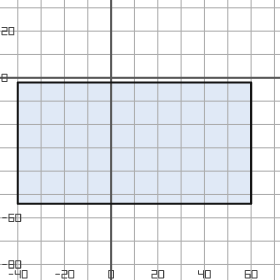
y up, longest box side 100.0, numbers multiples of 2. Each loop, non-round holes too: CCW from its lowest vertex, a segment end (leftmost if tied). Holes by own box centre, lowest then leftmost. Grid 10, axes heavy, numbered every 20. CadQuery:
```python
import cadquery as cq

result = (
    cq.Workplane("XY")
    .moveTo(-40.0, -54.0)
    .lineTo(60.0, -54.0)
    .lineTo(60.0, -2.0)
    .lineTo(-40.0, -2.0)
    .close()
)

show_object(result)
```